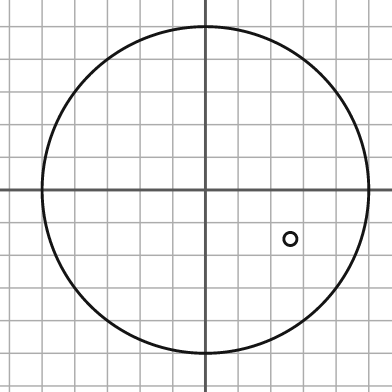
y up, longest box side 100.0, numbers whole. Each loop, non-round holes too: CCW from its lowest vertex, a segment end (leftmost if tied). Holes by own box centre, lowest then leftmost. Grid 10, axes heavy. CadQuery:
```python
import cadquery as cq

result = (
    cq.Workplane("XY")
    .moveTo(0.0, 0.0)
    .circle(50.0)
    .moveTo(26.0, -15.0)
    .circle(2.0)
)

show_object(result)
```